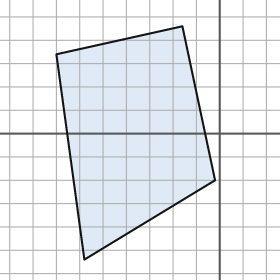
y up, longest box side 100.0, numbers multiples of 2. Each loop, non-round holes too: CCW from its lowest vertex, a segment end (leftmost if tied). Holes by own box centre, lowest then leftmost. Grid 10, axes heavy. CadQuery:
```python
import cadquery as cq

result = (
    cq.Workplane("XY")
    .moveTo(-58.0, -54.0)
    .lineTo(-2.0, -20.0)
    .lineTo(-16.0, 46.0)
    .lineTo(-70.0, 34.0)
    .close()
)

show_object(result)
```